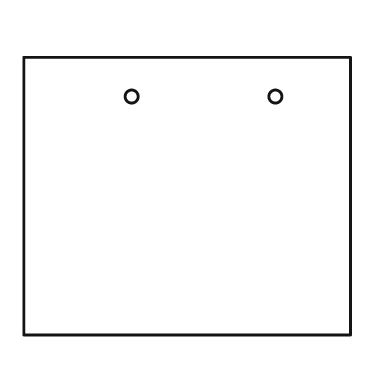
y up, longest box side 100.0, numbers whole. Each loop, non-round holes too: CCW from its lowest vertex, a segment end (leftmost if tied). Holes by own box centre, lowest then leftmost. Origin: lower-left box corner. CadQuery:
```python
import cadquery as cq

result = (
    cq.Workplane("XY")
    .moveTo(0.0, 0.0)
    .lineTo(100.0, 0.0)
    .lineTo(100.0, 85.0)
    .lineTo(0.0, 85.0)
    .close()
    .moveTo(33.0, 73.0)
    .circle(2.0)
    .moveTo(77.0, 73.0)
    .circle(2.0)
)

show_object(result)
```